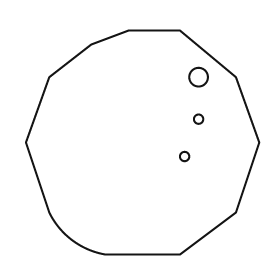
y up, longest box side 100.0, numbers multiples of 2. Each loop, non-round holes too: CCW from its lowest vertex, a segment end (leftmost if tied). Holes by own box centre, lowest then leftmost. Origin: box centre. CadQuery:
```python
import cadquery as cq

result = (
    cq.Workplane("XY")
    .moveTo(-16.0, -48.0)
    .lineTo(16.0, -48.0)
    .lineTo(40.0, -30.0)
    .lineTo(50.0, 0.0)
    .lineTo(40.0, 28.0)
    .lineTo(16.0, 48.0)
    .lineTo(-6.0, 48.0)
    .lineTo(-22.0, 42.0)
    .lineTo(-40.0, 28.0)
    .lineTo(-50.0, 0.0)
    .lineTo(-40.0, -30.0)
    .threePointArc((-30.0, -42.0), (-16.0, -48.0))
    .close()
    .moveTo(18.0, -6.0)
    .circle(2.0)
    .moveTo(24.0, 10.0)
    .circle(2.0)
    .moveTo(24.0, 28.0)
    .circle(4.0)
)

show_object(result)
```